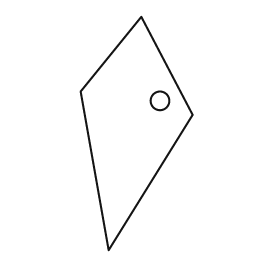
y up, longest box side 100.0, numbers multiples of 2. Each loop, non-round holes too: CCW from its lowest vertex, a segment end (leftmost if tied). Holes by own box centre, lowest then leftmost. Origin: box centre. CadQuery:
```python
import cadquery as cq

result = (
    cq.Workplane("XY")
    .moveTo(-12.0, -50.0)
    .lineTo(24.0, 8.0)
    .lineTo(2.0, 50.0)
    .lineTo(-24.0, 18.0)
    .close()
    .moveTo(10.0, 14.0)
    .circle(4.0)
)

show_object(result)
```